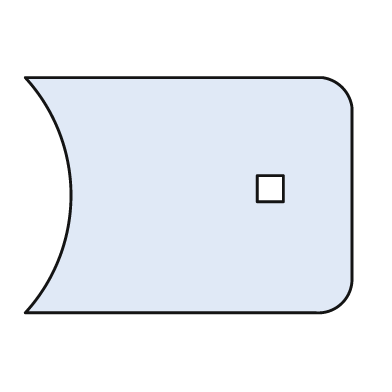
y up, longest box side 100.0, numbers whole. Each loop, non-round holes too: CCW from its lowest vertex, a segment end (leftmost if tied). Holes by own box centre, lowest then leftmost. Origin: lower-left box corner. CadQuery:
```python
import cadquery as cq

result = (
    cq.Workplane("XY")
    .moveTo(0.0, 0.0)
    .lineTo(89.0, 0.0)
    .threePointArc((97.0, 3.0), (100.0, 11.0))
    .lineTo(100.0, 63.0)
    .threePointArc((97.0, 69.0), (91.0, 72.0))
    .lineTo(0.0, 72.0)
    .threePointArc((14.0, 36.0), (0.0, 0.0))
    .close()
    .moveTo(71.0, 34.0)
    .lineTo(79.0, 34.0)
    .lineTo(79.0, 42.0)
    .lineTo(71.0, 42.0)
    .close()
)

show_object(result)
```